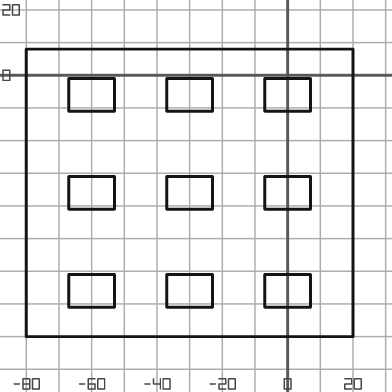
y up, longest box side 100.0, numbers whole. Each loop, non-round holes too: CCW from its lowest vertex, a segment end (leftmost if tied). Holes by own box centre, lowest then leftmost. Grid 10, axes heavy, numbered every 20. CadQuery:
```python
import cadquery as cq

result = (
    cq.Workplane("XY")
    .moveTo(-80.0, -80.0)
    .lineTo(20.0, -80.0)
    .lineTo(20.0, 8.0)
    .lineTo(-80.0, 8.0)
    .close()
    .moveTo(-67.0, -71.0)
    .lineTo(-53.0, -71.0)
    .lineTo(-53.0, -61.0)
    .lineTo(-67.0, -61.0)
    .close()
    .moveTo(-37.0, -71.0)
    .lineTo(-23.0, -71.0)
    .lineTo(-23.0, -61.0)
    .lineTo(-37.0, -61.0)
    .close()
    .moveTo(-7.0, -71.0)
    .lineTo(7.0, -71.0)
    .lineTo(7.0, -61.0)
    .lineTo(-7.0, -61.0)
    .close()
    .moveTo(-67.0, -41.0)
    .lineTo(-53.0, -41.0)
    .lineTo(-53.0, -31.0)
    .lineTo(-67.0, -31.0)
    .close()
    .moveTo(-37.0, -41.0)
    .lineTo(-23.0, -41.0)
    .lineTo(-23.0, -31.0)
    .lineTo(-37.0, -31.0)
    .close()
    .moveTo(-7.0, -41.0)
    .lineTo(7.0, -41.0)
    .lineTo(7.0, -31.0)
    .lineTo(-7.0, -31.0)
    .close()
    .moveTo(-67.0, -11.0)
    .lineTo(-53.0, -11.0)
    .lineTo(-53.0, -1.0)
    .lineTo(-67.0, -1.0)
    .close()
    .moveTo(-37.0, -11.0)
    .lineTo(-23.0, -11.0)
    .lineTo(-23.0, -1.0)
    .lineTo(-37.0, -1.0)
    .close()
    .moveTo(-7.0, -11.0)
    .lineTo(7.0, -11.0)
    .lineTo(7.0, -1.0)
    .lineTo(-7.0, -1.0)
    .close()
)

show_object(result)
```